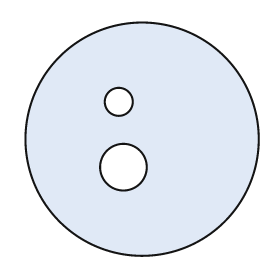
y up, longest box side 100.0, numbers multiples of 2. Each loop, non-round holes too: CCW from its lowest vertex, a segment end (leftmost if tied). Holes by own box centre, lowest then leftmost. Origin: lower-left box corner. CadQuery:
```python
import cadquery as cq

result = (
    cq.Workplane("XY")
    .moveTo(50.0, 50.0)
    .circle(50.0)
    .moveTo(42.0, 38.0)
    .circle(10.0)
    .moveTo(40.0, 66.0)
    .circle(6.0)
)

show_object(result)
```